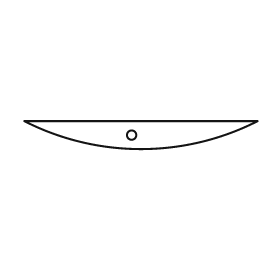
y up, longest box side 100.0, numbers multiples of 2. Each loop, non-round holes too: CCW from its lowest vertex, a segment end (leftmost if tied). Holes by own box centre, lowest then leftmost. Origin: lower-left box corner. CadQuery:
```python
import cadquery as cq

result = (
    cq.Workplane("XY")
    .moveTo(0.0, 12.0)
    .threePointArc((50.0, 0.0), (100.0, 12.0))
    .close()
    .moveTo(46.0, 6.0)
    .circle(2.0)
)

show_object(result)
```